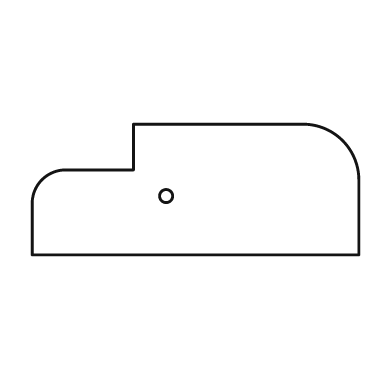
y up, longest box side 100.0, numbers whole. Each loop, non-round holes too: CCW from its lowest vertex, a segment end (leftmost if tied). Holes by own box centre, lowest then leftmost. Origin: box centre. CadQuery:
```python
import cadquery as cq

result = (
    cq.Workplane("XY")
    .moveTo(-50.0, -20.0)
    .lineTo(50.0, -20.0)
    .lineTo(50.0, 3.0)
    .threePointArc((45.0, 15.0), (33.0, 20.0))
    .lineTo(-19.0, 20.0)
    .lineTo(-19.0, 6.0)
    .lineTo(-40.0, 6.0)
    .threePointArc((-47.0, 3.0), (-50.0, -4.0))
    .close()
    .moveTo(-9.0, -2.0)
    .circle(2.0)
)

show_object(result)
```